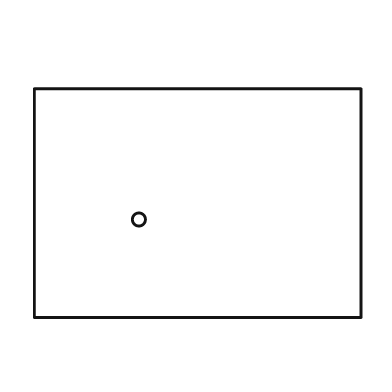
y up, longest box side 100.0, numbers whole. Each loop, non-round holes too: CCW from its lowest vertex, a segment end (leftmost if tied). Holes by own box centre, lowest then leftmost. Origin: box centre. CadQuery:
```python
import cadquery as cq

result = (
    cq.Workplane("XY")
    .moveTo(-50.0, -35.0)
    .lineTo(50.0, -35.0)
    .lineTo(50.0, 35.0)
    .lineTo(-50.0, 35.0)
    .close()
    .moveTo(-18.0, -5.0)
    .circle(2.0)
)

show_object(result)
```